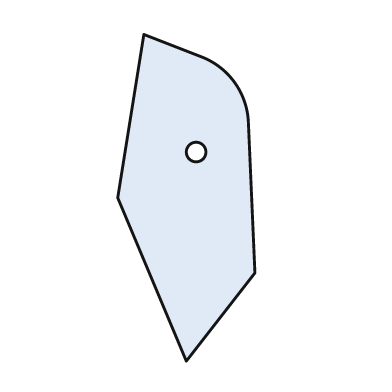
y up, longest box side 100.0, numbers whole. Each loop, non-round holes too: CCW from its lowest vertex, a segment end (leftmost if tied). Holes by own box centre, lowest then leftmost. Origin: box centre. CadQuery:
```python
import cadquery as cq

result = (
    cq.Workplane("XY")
    .moveTo(0.0, -50.0)
    .lineTo(21.0, -23.0)
    .lineTo(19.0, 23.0)
    .threePointArc((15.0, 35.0), (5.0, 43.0))
    .lineTo(-13.0, 50.0)
    .lineTo(-21.0, 0.0)
    .close()
    .moveTo(3.0, 14.0)
    .circle(3.0)
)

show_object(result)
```